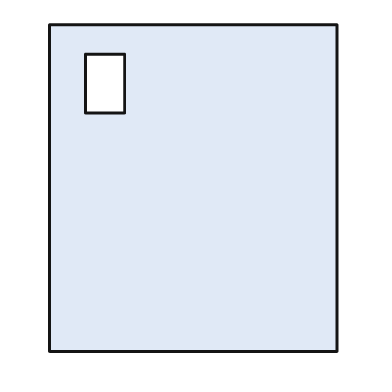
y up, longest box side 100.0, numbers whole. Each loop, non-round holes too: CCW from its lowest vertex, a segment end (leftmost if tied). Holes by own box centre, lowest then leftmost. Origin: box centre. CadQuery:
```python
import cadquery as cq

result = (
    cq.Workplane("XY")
    .moveTo(-44.0, -50.0)
    .lineTo(44.0, -50.0)
    .lineTo(44.0, 50.0)
    .lineTo(-44.0, 50.0)
    .close()
    .moveTo(-33.0, 23.0)
    .lineTo(-21.0, 23.0)
    .lineTo(-21.0, 41.0)
    .lineTo(-33.0, 41.0)
    .close()
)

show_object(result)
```